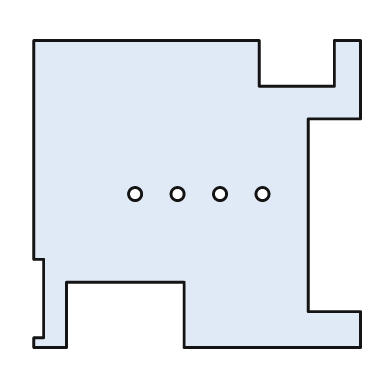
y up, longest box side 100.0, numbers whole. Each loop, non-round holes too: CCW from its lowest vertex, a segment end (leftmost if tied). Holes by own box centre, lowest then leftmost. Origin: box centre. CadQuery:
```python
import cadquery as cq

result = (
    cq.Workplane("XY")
    .moveTo(-50.0, -47.0)
    .lineTo(-40.0, -47.0)
    .lineTo(-40.0, -27.0)
    .lineTo(-4.0, -27.0)
    .lineTo(-4.0, -47.0)
    .lineTo(50.0, -47.0)
    .lineTo(50.0, -36.0)
    .lineTo(34.0, -36.0)
    .lineTo(34.0, 23.0)
    .lineTo(50.0, 23.0)
    .lineTo(50.0, 47.0)
    .lineTo(42.0, 47.0)
    .lineTo(42.0, 33.0)
    .lineTo(19.0, 33.0)
    .lineTo(19.0, 47.0)
    .lineTo(-50.0, 47.0)
    .lineTo(-50.0, -20.0)
    .lineTo(-47.0, -20.0)
    .lineTo(-47.0, -44.0)
    .lineTo(-50.0, -44.0)
    .close()
    .moveTo(-19.0, 0.0)
    .circle(2.0)
    .moveTo(-6.0, 0.0)
    .circle(2.0)
    .moveTo(7.0, 0.0)
    .circle(2.0)
    .moveTo(20.0, 0.0)
    .circle(2.0)
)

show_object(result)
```